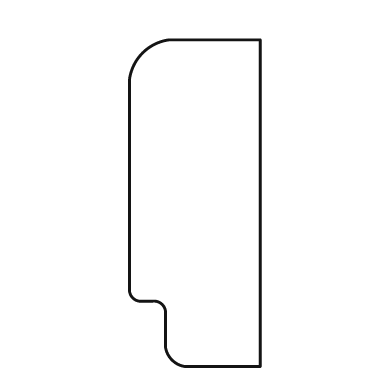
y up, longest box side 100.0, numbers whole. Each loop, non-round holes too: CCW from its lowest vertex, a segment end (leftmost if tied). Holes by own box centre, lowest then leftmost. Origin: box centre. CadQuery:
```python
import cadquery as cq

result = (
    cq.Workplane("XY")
    .moveTo(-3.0, -50.0)
    .lineTo(20.0, -50.0)
    .lineTo(20.0, 50.0)
    .lineTo(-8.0, 50.0)
    .threePointArc((-16.0, 46.0), (-20.0, 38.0))
    .lineTo(-20.0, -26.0)
    .threePointArc((-19.0, -29.0), (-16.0, -30.0))
    .lineTo(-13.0, -30.0)
    .threePointArc((-10.0, -31.0), (-9.0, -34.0))
    .lineTo(-9.0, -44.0)
    .threePointArc((-7.0, -48.0), (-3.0, -50.0))
    .close()
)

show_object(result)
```